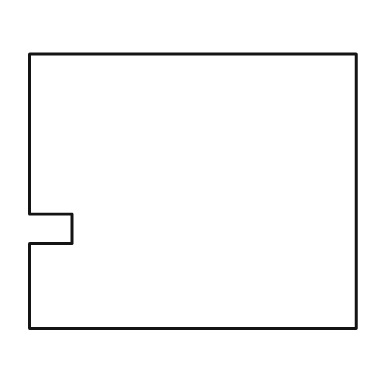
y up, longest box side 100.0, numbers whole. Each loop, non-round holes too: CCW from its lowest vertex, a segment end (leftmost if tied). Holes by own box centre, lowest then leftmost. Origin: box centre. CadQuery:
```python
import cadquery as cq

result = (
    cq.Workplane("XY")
    .moveTo(-50.0, -42.0)
    .lineTo(50.0, -42.0)
    .lineTo(50.0, 42.0)
    .lineTo(-50.0, 42.0)
    .lineTo(-50.0, -7.0)
    .lineTo(-37.0, -7.0)
    .lineTo(-37.0, -16.0)
    .lineTo(-50.0, -16.0)
    .close()
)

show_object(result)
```